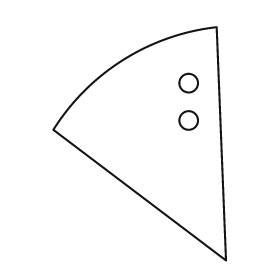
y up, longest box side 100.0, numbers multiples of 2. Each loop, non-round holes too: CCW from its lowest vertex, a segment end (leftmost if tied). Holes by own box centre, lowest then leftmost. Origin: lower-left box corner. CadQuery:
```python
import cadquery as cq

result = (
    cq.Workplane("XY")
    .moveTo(74.0, 0.0)
    .lineTo(70.0, 100.0)
    .threePointArc((30.0, 86.0), (0.0, 56.0))
    .close()
    .moveTo(58.0, 60.0)
    .circle(4.0)
    .moveTo(58.0, 76.0)
    .circle(4.0)
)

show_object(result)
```